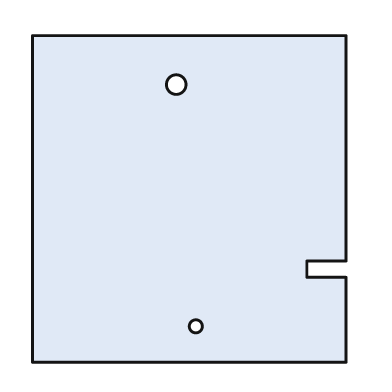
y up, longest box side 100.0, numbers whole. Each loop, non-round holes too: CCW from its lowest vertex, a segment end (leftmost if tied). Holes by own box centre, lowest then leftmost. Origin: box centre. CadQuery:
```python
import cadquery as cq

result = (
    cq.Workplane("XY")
    .moveTo(-48.0, -50.0)
    .lineTo(48.0, -50.0)
    .lineTo(48.0, -24.0)
    .lineTo(36.0, -24.0)
    .lineTo(36.0, -19.0)
    .lineTo(48.0, -19.0)
    .lineTo(48.0, 50.0)
    .lineTo(-48.0, 50.0)
    .close()
    .moveTo(2.0, -39.0)
    .circle(2.0)
    .moveTo(-4.0, 35.0)
    .circle(3.0)
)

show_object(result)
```